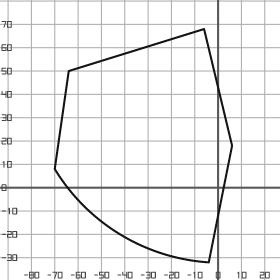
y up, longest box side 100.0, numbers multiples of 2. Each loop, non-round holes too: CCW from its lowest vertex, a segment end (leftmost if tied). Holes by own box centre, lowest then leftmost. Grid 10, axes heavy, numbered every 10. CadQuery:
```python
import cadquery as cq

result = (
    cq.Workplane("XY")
    .moveTo(-4.0, -32.0)
    .lineTo(6.0, 18.0)
    .lineTo(-6.0, 68.0)
    .lineTo(-64.0, 50.0)
    .lineTo(-70.0, 8.0)
    .threePointArc((-42.0, -20.0), (-4.0, -32.0))
    .close()
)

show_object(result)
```